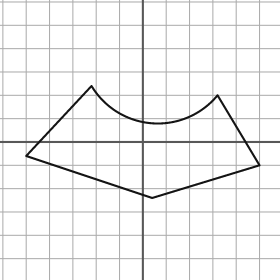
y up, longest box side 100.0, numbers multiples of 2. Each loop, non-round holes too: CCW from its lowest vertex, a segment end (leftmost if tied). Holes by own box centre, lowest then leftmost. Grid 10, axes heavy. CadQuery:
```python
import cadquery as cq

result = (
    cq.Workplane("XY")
    .moveTo(4.0, -24.0)
    .lineTo(50.0, -10.0)
    .lineTo(32.0, 20.0)
    .threePointArc((4.0, 8.0), (-22.0, 24.0))
    .lineTo(-50.0, -6.0)
    .close()
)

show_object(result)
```